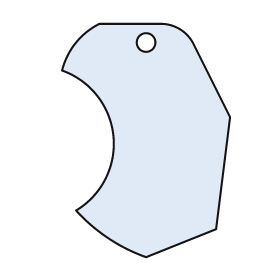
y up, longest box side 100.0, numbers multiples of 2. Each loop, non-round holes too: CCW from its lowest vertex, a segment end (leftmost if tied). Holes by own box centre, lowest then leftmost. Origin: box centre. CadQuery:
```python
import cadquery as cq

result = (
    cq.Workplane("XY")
    .moveTo(0.0, -50.0)
    .lineTo(30.0, -38.0)
    .lineTo(36.0, 10.0)
    .lineTo(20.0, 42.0)
    .threePointArc((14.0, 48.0), (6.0, 50.0))
    .lineTo(-20.0, 50.0)
    .threePointArc((-30.0, 42.0), (-36.0, 30.0))
    .threePointArc((-14.0, 2.0), (-30.0, -30.0))
    .threePointArc((-16.0, -42.0), (0.0, -50.0))
    .close()
    .moveTo(0.0, 42.0)
    .circle(4.0)
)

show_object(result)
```